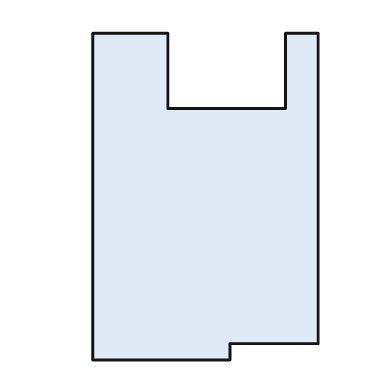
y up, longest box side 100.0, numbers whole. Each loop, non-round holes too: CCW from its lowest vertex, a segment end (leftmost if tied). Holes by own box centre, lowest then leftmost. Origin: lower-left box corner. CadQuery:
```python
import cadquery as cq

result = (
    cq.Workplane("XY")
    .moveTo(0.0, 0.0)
    .lineTo(42.0, 0.0)
    .lineTo(42.0, 5.0)
    .lineTo(69.0, 5.0)
    .lineTo(69.0, 100.0)
    .lineTo(59.0, 100.0)
    .lineTo(59.0, 77.0)
    .lineTo(23.0, 77.0)
    .lineTo(23.0, 100.0)
    .lineTo(0.0, 100.0)
    .close()
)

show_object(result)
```